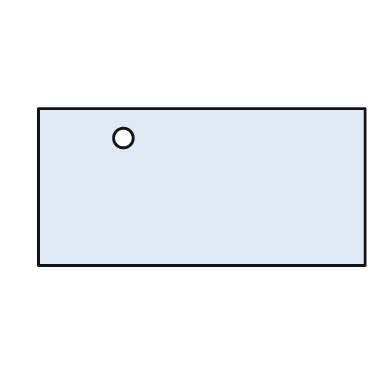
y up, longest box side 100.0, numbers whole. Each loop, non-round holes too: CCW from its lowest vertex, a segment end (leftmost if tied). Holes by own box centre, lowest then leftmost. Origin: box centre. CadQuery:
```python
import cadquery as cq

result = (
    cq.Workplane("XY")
    .moveTo(-50.0, -24.0)
    .lineTo(50.0, -24.0)
    .lineTo(50.0, 24.0)
    .lineTo(-50.0, 24.0)
    .close()
    .moveTo(-24.0, 15.0)
    .circle(3.0)
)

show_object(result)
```